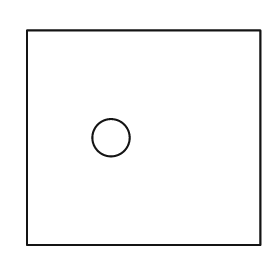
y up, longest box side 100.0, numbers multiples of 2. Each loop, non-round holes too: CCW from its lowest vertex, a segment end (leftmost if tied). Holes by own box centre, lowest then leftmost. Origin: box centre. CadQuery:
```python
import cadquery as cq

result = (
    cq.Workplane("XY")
    .moveTo(-50.0, -46.0)
    .lineTo(50.0, -46.0)
    .lineTo(50.0, 46.0)
    .lineTo(-50.0, 46.0)
    .close()
    .moveTo(-14.0, 0.0)
    .circle(8.0)
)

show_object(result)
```